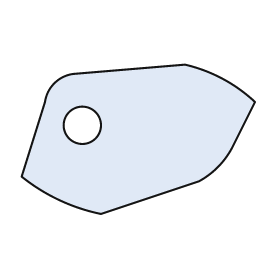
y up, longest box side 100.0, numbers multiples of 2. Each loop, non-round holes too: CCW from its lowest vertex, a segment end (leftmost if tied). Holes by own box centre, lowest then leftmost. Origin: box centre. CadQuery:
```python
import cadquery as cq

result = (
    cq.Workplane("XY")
    .moveTo(-16.0, -32.0)
    .lineTo(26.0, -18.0)
    .threePointArc((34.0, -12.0), (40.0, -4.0))
    .lineTo(50.0, 16.0)
    .threePointArc((36.0, 26.0), (20.0, 32.0))
    .lineTo(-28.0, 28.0)
    .threePointArc((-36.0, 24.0), (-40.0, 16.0))
    .lineTo(-50.0, -16.0)
    .threePointArc((-34.0, -26.0), (-16.0, -32.0))
    .close()
    .moveTo(-24.0, 6.0)
    .circle(8.0)
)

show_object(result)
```